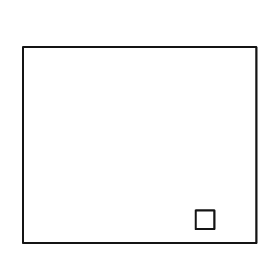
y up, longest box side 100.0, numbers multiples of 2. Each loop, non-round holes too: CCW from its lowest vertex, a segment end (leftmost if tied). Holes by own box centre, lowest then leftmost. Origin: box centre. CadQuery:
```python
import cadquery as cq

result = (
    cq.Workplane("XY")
    .moveTo(-50.0, -42.0)
    .lineTo(50.0, -42.0)
    .lineTo(50.0, 42.0)
    .lineTo(-50.0, 42.0)
    .close()
    .moveTo(24.0, -36.0)
    .lineTo(32.0, -36.0)
    .lineTo(32.0, -28.0)
    .lineTo(24.0, -28.0)
    .close()
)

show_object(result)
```